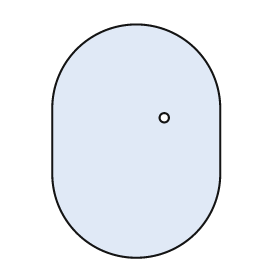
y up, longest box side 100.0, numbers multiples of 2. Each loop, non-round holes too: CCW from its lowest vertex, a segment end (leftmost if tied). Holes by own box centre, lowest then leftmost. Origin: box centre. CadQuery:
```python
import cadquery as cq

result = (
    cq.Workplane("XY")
    .moveTo(-36.0, -14.0)
    .threePointArc((0.0, -50.0), (36.0, -14.0))
    .lineTo(36.0, 14.0)
    .threePointArc((0.0, 50.0), (-36.0, 14.0))
    .close()
    .moveTo(12.0, 10.0)
    .circle(2.0)
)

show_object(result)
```